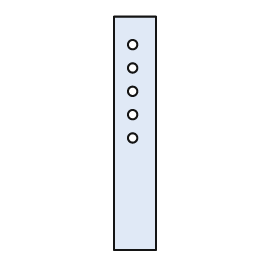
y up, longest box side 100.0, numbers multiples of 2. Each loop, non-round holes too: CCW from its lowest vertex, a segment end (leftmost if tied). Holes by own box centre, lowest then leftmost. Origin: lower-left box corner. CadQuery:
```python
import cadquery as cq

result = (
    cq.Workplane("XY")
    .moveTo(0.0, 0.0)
    .lineTo(18.0, 0.0)
    .lineTo(18.0, 100.0)
    .lineTo(0.0, 100.0)
    .close()
    .moveTo(8.0, 48.0)
    .circle(2.0)
    .moveTo(8.0, 58.0)
    .circle(2.0)
    .moveTo(8.0, 68.0)
    .circle(2.0)
    .moveTo(8.0, 78.0)
    .circle(2.0)
    .moveTo(8.0, 88.0)
    .circle(2.0)
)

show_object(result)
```